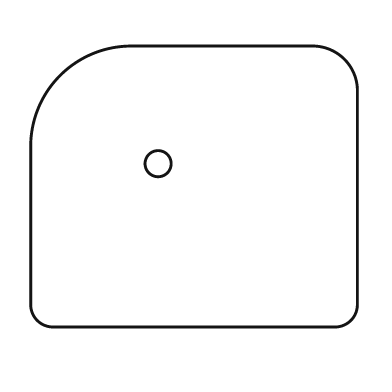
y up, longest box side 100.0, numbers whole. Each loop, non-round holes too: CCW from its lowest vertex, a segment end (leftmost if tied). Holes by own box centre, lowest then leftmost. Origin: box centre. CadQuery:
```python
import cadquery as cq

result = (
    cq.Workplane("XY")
    .moveTo(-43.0, -43.0)
    .lineTo(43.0, -43.0)
    .threePointArc((48.0, -41.0), (50.0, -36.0))
    .lineTo(50.0, 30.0)
    .threePointArc((46.0, 39.0), (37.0, 43.0))
    .lineTo(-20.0, 43.0)
    .threePointArc((-41.0, 34.0), (-50.0, 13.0))
    .lineTo(-50.0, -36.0)
    .threePointArc((-48.0, -41.0), (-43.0, -43.0))
    .close()
    .moveTo(-11.0, 7.0)
    .circle(4.0)
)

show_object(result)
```